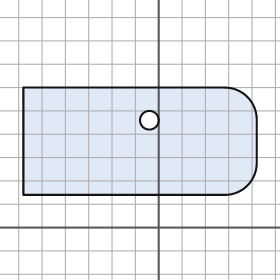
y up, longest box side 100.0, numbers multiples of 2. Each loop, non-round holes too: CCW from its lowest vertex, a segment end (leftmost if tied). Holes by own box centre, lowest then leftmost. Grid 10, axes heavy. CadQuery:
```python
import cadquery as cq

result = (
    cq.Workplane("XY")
    .moveTo(-58.0, 14.0)
    .lineTo(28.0, 14.0)
    .threePointArc((38.0, 18.0), (42.0, 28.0))
    .lineTo(42.0, 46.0)
    .threePointArc((38.0, 56.0), (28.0, 60.0))
    .lineTo(-58.0, 60.0)
    .close()
    .moveTo(-4.0, 46.0)
    .circle(4.0)
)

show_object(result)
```